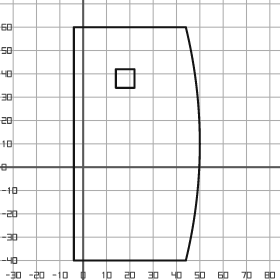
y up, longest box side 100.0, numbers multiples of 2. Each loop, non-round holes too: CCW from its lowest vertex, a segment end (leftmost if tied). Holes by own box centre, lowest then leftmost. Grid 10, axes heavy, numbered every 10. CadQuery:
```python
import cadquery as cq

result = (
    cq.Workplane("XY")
    .moveTo(-4.0, -40.0)
    .lineTo(44.0, -40.0)
    .threePointArc((50.0, 10.0), (44.0, 60.0))
    .lineTo(-4.0, 60.0)
    .close()
    .moveTo(14.0, 34.0)
    .lineTo(22.0, 34.0)
    .lineTo(22.0, 42.0)
    .lineTo(14.0, 42.0)
    .close()
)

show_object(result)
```